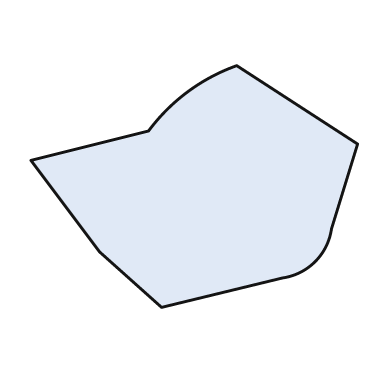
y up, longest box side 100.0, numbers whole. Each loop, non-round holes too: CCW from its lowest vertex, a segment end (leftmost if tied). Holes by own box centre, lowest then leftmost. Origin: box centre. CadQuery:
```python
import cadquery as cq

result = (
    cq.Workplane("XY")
    .moveTo(-10.0, -37.0)
    .lineTo(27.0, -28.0)
    .threePointArc((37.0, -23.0), (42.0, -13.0))
    .lineTo(50.0, 13.0)
    .lineTo(13.0, 37.0)
    .threePointArc((-2.0, 29.0), (-14.0, 17.0))
    .lineTo(-50.0, 8.0)
    .lineTo(-29.0, -20.0)
    .close()
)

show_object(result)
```